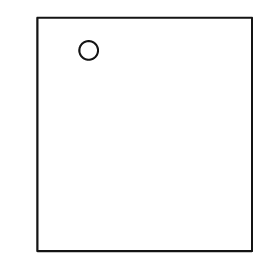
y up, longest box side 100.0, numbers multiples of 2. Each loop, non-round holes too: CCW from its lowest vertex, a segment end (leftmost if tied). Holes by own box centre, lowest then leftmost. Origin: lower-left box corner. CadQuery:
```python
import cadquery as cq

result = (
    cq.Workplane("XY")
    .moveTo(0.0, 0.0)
    .lineTo(92.0, 0.0)
    .lineTo(92.0, 100.0)
    .lineTo(0.0, 100.0)
    .close()
    .moveTo(22.0, 86.0)
    .circle(4.0)
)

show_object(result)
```